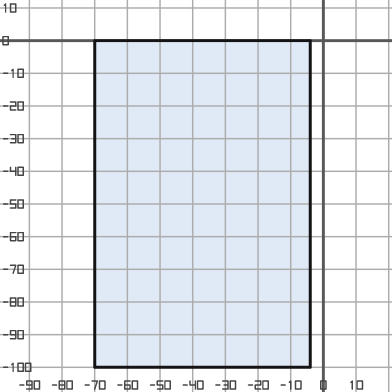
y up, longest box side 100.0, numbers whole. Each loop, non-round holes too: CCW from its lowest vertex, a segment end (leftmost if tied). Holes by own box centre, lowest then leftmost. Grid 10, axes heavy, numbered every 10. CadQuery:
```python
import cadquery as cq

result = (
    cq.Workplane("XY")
    .moveTo(-70.0, -100.0)
    .lineTo(-4.0, -100.0)
    .lineTo(-4.0, 0.0)
    .lineTo(-70.0, 0.0)
    .close()
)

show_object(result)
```